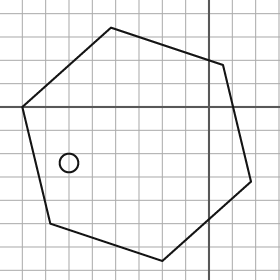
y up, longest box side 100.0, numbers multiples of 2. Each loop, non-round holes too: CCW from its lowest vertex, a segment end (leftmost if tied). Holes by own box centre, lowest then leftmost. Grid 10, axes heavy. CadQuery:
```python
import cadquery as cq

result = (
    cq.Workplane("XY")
    .moveTo(-20.0, -66.0)
    .lineTo(18.0, -32.0)
    .lineTo(6.0, 18.0)
    .lineTo(-42.0, 34.0)
    .lineTo(-80.0, 0.0)
    .lineTo(-68.0, -50.0)
    .close()
    .moveTo(-60.0, -24.0)
    .circle(4.0)
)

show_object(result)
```